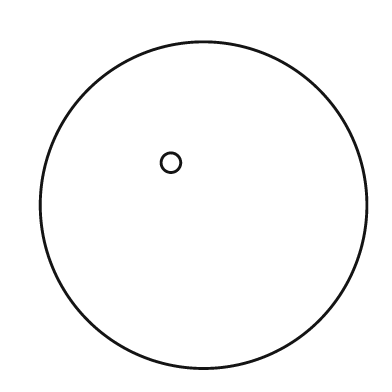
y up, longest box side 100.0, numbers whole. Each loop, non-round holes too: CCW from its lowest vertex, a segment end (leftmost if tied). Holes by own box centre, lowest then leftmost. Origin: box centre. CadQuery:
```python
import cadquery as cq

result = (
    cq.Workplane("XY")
    .moveTo(0.0, 0.0)
    .circle(50.0)
    .moveTo(-10.0, 13.0)
    .circle(3.0)
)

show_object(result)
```